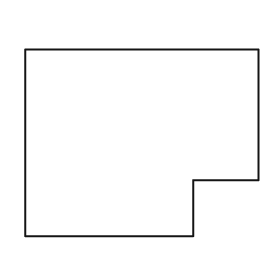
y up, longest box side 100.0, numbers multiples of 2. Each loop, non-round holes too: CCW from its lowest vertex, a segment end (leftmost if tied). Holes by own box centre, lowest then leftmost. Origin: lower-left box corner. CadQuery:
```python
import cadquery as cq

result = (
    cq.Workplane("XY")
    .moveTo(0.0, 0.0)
    .lineTo(72.0, 0.0)
    .lineTo(72.0, 24.0)
    .lineTo(100.0, 24.0)
    .lineTo(100.0, 80.0)
    .lineTo(0.0, 80.0)
    .close()
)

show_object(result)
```